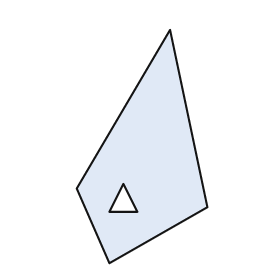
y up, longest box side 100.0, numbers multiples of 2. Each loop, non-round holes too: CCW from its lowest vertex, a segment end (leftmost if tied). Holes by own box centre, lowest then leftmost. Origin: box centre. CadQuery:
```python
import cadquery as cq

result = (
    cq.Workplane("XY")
    .moveTo(-14.0, -50.0)
    .lineTo(28.0, -26.0)
    .lineTo(12.0, 50.0)
    .lineTo(-28.0, -18.0)
    .close()
    .moveTo(-14.0, -28.0)
    .lineTo(-2.0, -28.0)
    .lineTo(-8.0, -16.0)
    .close()
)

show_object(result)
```